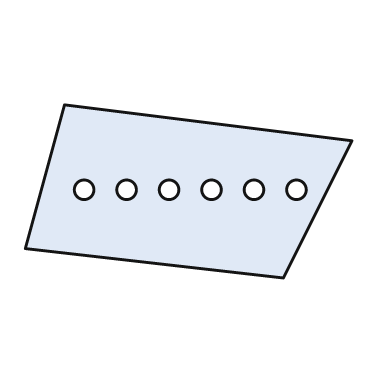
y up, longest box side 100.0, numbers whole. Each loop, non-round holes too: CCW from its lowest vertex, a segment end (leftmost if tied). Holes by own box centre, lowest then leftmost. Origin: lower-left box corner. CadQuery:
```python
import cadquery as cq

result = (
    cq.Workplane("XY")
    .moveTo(79.0, 0.0)
    .lineTo(100.0, 42.0)
    .lineTo(12.0, 53.0)
    .lineTo(0.0, 9.0)
    .close()
    .moveTo(18.0, 27.0)
    .circle(3.0)
    .moveTo(31.0, 27.0)
    .circle(3.0)
    .moveTo(44.0, 27.0)
    .circle(3.0)
    .moveTo(57.0, 27.0)
    .circle(3.0)
    .moveTo(70.0, 27.0)
    .circle(3.0)
    .moveTo(83.0, 27.0)
    .circle(3.0)
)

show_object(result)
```